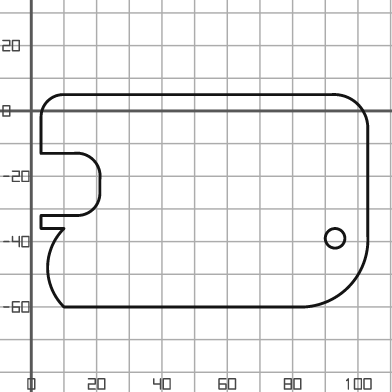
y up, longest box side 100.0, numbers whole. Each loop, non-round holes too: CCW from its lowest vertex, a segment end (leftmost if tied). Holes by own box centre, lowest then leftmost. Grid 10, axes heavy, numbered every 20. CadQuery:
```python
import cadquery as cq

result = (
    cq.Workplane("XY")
    .moveTo(10.0, -60.0)
    .lineTo(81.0, -60.0)
    .threePointArc((97.0, -54.0), (103.0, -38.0))
    .lineTo(103.0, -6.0)
    .threePointArc((100.0, 2.0), (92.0, 5.0))
    .lineTo(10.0, 5.0)
    .threePointArc((5.0, 3.0), (3.0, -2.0))
    .lineTo(3.0, -13.0)
    .lineTo(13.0, -13.0)
    .threePointArc((19.0, -15.0), (21.0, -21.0))
    .lineTo(21.0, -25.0)
    .threePointArc((19.0, -30.0), (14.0, -32.0))
    .lineTo(3.0, -32.0)
    .lineTo(3.0, -36.0)
    .lineTo(10.0, -36.0)
    .threePointArc((5.0, -48.0), (10.0, -60.0))
    .close()
    .moveTo(93.0, -39.0)
    .circle(3.0)
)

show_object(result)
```